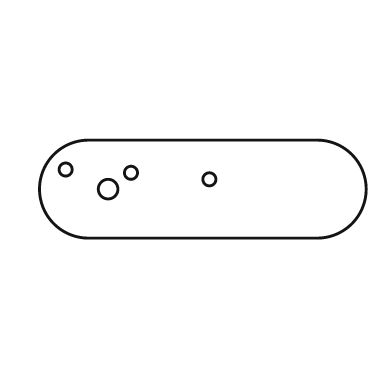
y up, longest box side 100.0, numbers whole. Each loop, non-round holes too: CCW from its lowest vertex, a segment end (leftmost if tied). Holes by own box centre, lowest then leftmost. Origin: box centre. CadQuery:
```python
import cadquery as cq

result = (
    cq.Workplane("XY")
    .moveTo(-35.0, -15.0)
    .lineTo(35.0, -15.0)
    .threePointArc((50.0, 0.0), (35.0, 15.0))
    .lineTo(-35.0, 15.0)
    .threePointArc((-50.0, 0.0), (-35.0, -15.0))
    .close()
    .moveTo(-29.0, 0.0)
    .circle(3.0)
    .moveTo(2.0, 3.0)
    .circle(2.0)
    .moveTo(-22.0, 5.0)
    .circle(2.0)
    .moveTo(-42.0, 6.0)
    .circle(2.0)
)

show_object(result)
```